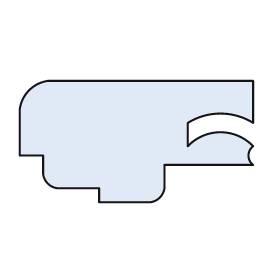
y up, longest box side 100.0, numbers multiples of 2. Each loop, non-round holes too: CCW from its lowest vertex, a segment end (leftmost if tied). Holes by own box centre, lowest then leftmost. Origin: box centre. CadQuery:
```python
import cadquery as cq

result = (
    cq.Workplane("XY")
    .moveTo(-16.0, -26.0)
    .lineTo(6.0, -26.0)
    .threePointArc((10.0, -24.0), (12.0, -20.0))
    .lineTo(12.0, -10.0)
    .lineTo(50.0, -10.0)
    .threePointArc((48.0, -6.0), (50.0, -2.0))
    .threePointArc((36.0, 4.0), (22.0, -2.0))
    .lineTo(22.0, 8.0)
    .threePointArc((36.0, 12.0), (50.0, 8.0))
    .lineTo(50.0, 26.0)
    .lineTo(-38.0, 26.0)
    .threePointArc((-46.0, 22.0), (-50.0, 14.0))
    .lineTo(-50.0, -6.0)
    .lineTo(-40.0, -6.0)
    .lineTo(-40.0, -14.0)
    .threePointArc((-38.0, -18.0), (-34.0, -20.0))
    .lineTo(-16.0, -20.0)
    .close()
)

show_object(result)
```